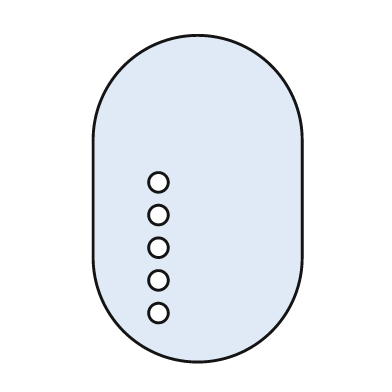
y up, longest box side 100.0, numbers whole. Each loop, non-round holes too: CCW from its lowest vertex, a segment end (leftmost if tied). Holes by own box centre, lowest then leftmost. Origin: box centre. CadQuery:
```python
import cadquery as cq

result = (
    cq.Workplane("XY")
    .moveTo(-32.0, -18.0)
    .threePointArc((0.0, -50.0), (32.0, -18.0))
    .lineTo(32.0, 18.0)
    .threePointArc((0.0, 50.0), (-32.0, 18.0))
    .close()
    .moveTo(-12.0, -35.0)
    .circle(3.0)
    .moveTo(-12.0, -25.0)
    .circle(3.0)
    .moveTo(-12.0, -15.0)
    .circle(3.0)
    .moveTo(-12.0, -5.0)
    .circle(3.0)
    .moveTo(-12.0, 5.0)
    .circle(3.0)
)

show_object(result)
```